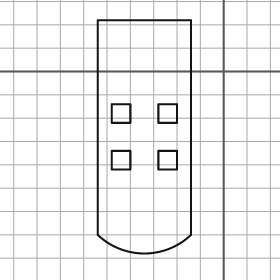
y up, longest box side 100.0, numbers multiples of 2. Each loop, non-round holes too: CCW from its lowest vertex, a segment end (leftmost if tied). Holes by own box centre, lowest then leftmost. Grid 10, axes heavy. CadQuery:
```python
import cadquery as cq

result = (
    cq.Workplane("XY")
    .moveTo(-54.0, -70.0)
    .threePointArc((-34.0, -78.0), (-14.0, -70.0))
    .lineTo(-14.0, 22.0)
    .lineTo(-54.0, 22.0)
    .close()
    .moveTo(-48.0, -42.0)
    .lineTo(-40.0, -42.0)
    .lineTo(-40.0, -34.0)
    .lineTo(-48.0, -34.0)
    .close()
    .moveTo(-28.0, -42.0)
    .lineTo(-20.0, -42.0)
    .lineTo(-20.0, -34.0)
    .lineTo(-28.0, -34.0)
    .close()
    .moveTo(-48.0, -22.0)
    .lineTo(-40.0, -22.0)
    .lineTo(-40.0, -14.0)
    .lineTo(-48.0, -14.0)
    .close()
    .moveTo(-28.0, -22.0)
    .lineTo(-20.0, -22.0)
    .lineTo(-20.0, -14.0)
    .lineTo(-28.0, -14.0)
    .close()
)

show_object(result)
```